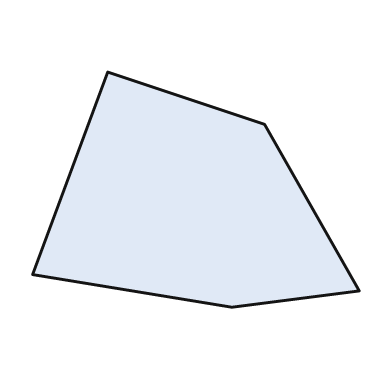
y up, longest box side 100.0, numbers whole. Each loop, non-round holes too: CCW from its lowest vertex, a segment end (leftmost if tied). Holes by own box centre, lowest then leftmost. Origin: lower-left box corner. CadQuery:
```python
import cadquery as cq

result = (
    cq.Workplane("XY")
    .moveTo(61.0, 0.0)
    .lineTo(100.0, 5.0)
    .lineTo(71.0, 56.0)
    .lineTo(23.0, 72.0)
    .lineTo(0.0, 10.0)
    .close()
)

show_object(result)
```